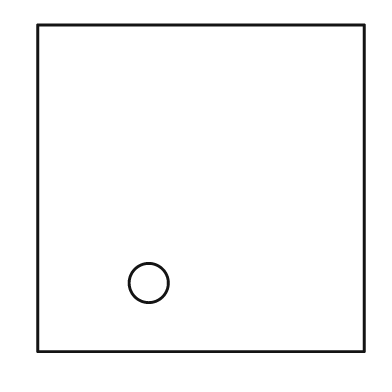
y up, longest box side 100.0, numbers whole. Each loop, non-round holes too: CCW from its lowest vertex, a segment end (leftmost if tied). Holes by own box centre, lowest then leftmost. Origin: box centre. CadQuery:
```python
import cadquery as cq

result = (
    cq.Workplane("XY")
    .moveTo(-50.0, -50.0)
    .lineTo(50.0, -50.0)
    .lineTo(50.0, 50.0)
    .lineTo(-50.0, 50.0)
    .close()
    .moveTo(-16.0, -29.0)
    .circle(6.0)
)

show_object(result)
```